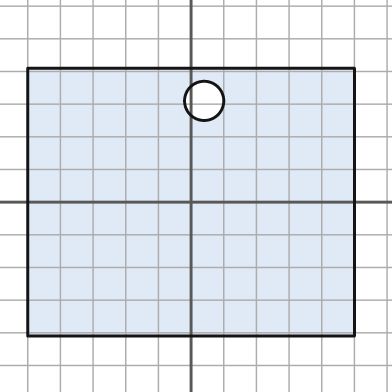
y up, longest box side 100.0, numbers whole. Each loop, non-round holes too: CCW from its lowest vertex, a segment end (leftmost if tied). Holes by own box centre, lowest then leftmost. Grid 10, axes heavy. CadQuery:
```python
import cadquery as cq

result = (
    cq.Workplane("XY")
    .moveTo(-50.0, -41.0)
    .lineTo(50.0, -41.0)
    .lineTo(50.0, 41.0)
    .lineTo(-50.0, 41.0)
    .close()
    .moveTo(4.0, 31.0)
    .circle(6.0)
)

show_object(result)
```